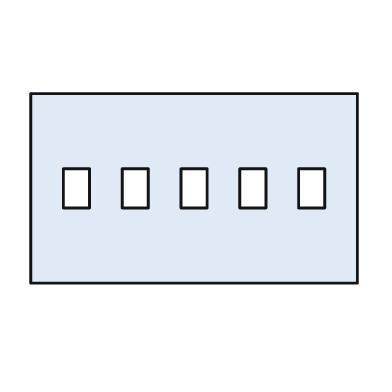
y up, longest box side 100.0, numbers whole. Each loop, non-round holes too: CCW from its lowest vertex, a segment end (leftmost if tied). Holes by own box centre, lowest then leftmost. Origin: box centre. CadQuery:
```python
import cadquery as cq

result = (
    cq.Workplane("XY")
    .moveTo(-50.0, -29.0)
    .lineTo(50.0, -29.0)
    .lineTo(50.0, 29.0)
    .lineTo(-50.0, 29.0)
    .close()
    .moveTo(-40.0, -6.0)
    .lineTo(-32.0, -6.0)
    .lineTo(-32.0, 6.0)
    .lineTo(-40.0, 6.0)
    .close()
    .moveTo(-22.0, -6.0)
    .lineTo(-14.0, -6.0)
    .lineTo(-14.0, 6.0)
    .lineTo(-22.0, 6.0)
    .close()
    .moveTo(-4.0, -6.0)
    .lineTo(4.0, -6.0)
    .lineTo(4.0, 6.0)
    .lineTo(-4.0, 6.0)
    .close()
    .moveTo(14.0, -6.0)
    .lineTo(22.0, -6.0)
    .lineTo(22.0, 6.0)
    .lineTo(14.0, 6.0)
    .close()
    .moveTo(32.0, -6.0)
    .lineTo(40.0, -6.0)
    .lineTo(40.0, 6.0)
    .lineTo(32.0, 6.0)
    .close()
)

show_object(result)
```